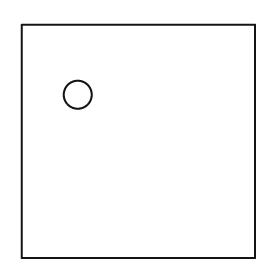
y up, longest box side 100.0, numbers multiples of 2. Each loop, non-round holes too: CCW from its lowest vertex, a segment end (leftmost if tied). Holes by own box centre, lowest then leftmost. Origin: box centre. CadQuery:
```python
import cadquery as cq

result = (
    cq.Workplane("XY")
    .moveTo(-50.0, -50.0)
    .lineTo(50.0, -50.0)
    .lineTo(50.0, 50.0)
    .lineTo(-50.0, 50.0)
    .close()
    .moveTo(-26.0, 20.0)
    .circle(6.0)
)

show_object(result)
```